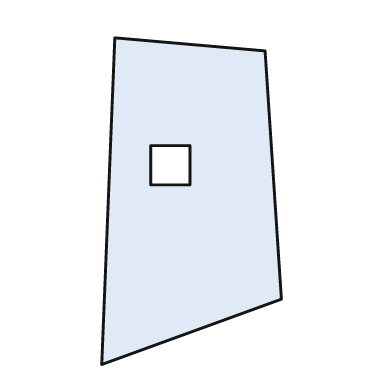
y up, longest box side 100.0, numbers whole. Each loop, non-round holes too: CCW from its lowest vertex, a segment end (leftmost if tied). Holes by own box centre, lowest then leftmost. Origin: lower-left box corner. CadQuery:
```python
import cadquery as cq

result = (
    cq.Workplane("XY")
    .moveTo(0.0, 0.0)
    .lineTo(55.0, 20.0)
    .lineTo(50.0, 96.0)
    .lineTo(4.0, 100.0)
    .close()
    .moveTo(15.0, 55.0)
    .lineTo(27.0, 55.0)
    .lineTo(27.0, 67.0)
    .lineTo(15.0, 67.0)
    .close()
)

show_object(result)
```